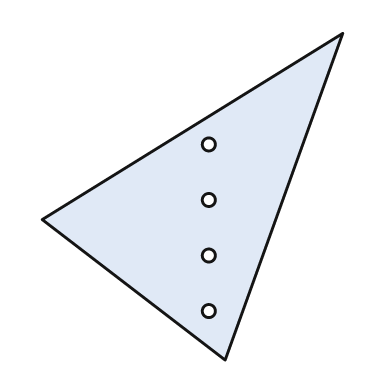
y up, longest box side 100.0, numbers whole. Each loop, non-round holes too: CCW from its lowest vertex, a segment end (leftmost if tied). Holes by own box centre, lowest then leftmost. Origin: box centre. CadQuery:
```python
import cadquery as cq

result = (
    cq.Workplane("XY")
    .moveTo(10.0, -50.0)
    .lineTo(46.0, 50.0)
    .lineTo(-46.0, -7.0)
    .close()
    .moveTo(5.0, -35.0)
    .circle(2.0)
    .moveTo(5.0, -18.0)
    .circle(2.0)
    .moveTo(5.0, -1.0)
    .circle(2.0)
    .moveTo(5.0, 16.0)
    .circle(2.0)
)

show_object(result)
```